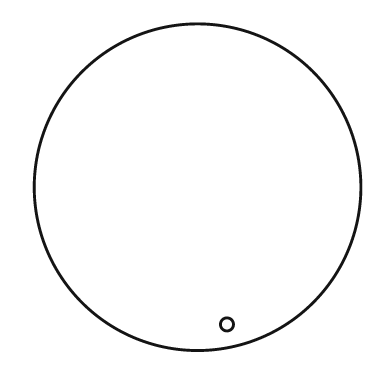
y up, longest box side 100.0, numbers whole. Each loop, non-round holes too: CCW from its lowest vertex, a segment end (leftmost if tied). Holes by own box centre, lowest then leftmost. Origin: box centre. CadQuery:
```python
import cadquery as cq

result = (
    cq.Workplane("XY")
    .moveTo(0.0, 0.0)
    .circle(50.0)
    .moveTo(9.0, -42.0)
    .circle(2.0)
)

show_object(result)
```